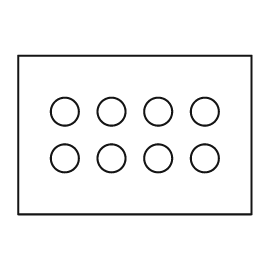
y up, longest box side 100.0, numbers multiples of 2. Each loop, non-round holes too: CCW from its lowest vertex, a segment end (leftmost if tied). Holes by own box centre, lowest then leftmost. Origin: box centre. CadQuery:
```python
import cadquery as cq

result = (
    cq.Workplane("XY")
    .moveTo(-50.0, -34.0)
    .lineTo(50.0, -34.0)
    .lineTo(50.0, 34.0)
    .lineTo(-50.0, 34.0)
    .close()
    .moveTo(-30.0, -10.0)
    .circle(6.0)
    .moveTo(-10.0, -10.0)
    .circle(6.0)
    .moveTo(10.0, -10.0)
    .circle(6.0)
    .moveTo(30.0, -10.0)
    .circle(6.0)
    .moveTo(-30.0, 10.0)
    .circle(6.0)
    .moveTo(-10.0, 10.0)
    .circle(6.0)
    .moveTo(10.0, 10.0)
    .circle(6.0)
    .moveTo(30.0, 10.0)
    .circle(6.0)
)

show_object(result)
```